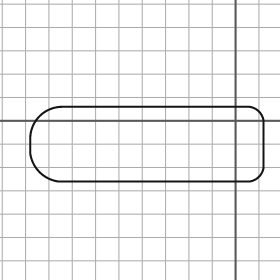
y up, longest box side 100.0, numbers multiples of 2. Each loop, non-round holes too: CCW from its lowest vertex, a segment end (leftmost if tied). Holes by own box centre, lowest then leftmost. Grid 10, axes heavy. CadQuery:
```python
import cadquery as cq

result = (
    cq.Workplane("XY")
    .moveTo(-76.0, -26.0)
    .lineTo(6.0, -26.0)
    .threePointArc((10.0, -24.0), (12.0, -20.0))
    .lineTo(12.0, 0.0)
    .threePointArc((10.0, 4.0), (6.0, 6.0))
    .lineTo(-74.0, 6.0)
    .threePointArc((-84.0, 2.0), (-88.0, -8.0))
    .lineTo(-88.0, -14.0)
    .threePointArc((-84.0, -22.0), (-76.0, -26.0))
    .close()
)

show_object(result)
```